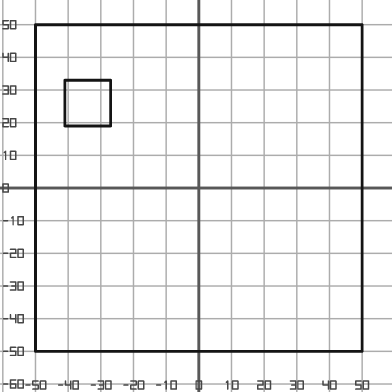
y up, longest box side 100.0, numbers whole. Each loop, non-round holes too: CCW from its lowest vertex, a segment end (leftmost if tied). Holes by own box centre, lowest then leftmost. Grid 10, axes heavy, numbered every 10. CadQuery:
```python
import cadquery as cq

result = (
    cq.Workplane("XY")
    .moveTo(-50.0, -50.0)
    .lineTo(50.0, -50.0)
    .lineTo(50.0, 50.0)
    .lineTo(-50.0, 50.0)
    .close()
    .moveTo(-41.0, 19.0)
    .lineTo(-27.0, 19.0)
    .lineTo(-27.0, 33.0)
    .lineTo(-41.0, 33.0)
    .close()
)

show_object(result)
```